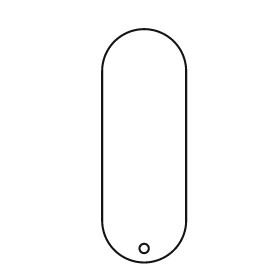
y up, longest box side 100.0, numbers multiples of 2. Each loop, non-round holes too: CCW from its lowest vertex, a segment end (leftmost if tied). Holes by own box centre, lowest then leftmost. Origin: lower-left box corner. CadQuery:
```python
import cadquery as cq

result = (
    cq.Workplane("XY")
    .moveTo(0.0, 18.0)
    .threePointArc((18.0, 0.0), (36.0, 18.0))
    .lineTo(36.0, 82.0)
    .threePointArc((18.0, 100.0), (0.0, 82.0))
    .close()
    .moveTo(18.0, 6.0)
    .circle(2.0)
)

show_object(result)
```